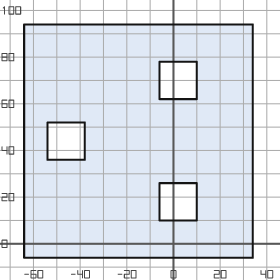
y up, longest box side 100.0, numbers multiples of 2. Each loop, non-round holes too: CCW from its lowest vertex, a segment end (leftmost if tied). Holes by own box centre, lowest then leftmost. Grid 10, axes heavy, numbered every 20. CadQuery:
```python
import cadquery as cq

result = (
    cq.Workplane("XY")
    .moveTo(-64.0, -6.0)
    .lineTo(34.0, -6.0)
    .lineTo(34.0, 94.0)
    .lineTo(-64.0, 94.0)
    .close()
    .moveTo(-6.0, 10.0)
    .lineTo(10.0, 10.0)
    .lineTo(10.0, 26.0)
    .lineTo(-6.0, 26.0)
    .close()
    .moveTo(-54.0, 36.0)
    .lineTo(-38.0, 36.0)
    .lineTo(-38.0, 52.0)
    .lineTo(-54.0, 52.0)
    .close()
    .moveTo(-6.0, 62.0)
    .lineTo(10.0, 62.0)
    .lineTo(10.0, 78.0)
    .lineTo(-6.0, 78.0)
    .close()
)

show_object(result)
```